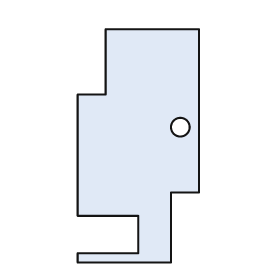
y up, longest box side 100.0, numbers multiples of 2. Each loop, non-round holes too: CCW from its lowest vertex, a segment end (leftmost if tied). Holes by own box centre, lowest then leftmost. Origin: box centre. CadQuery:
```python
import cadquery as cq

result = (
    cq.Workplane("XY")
    .moveTo(-26.0, -50.0)
    .lineTo(14.0, -50.0)
    .lineTo(14.0, -20.0)
    .lineTo(26.0, -20.0)
    .lineTo(26.0, 50.0)
    .lineTo(-14.0, 50.0)
    .lineTo(-14.0, 22.0)
    .lineTo(-26.0, 22.0)
    .lineTo(-26.0, -30.0)
    .lineTo(0.0, -30.0)
    .lineTo(0.0, -46.0)
    .lineTo(-26.0, -46.0)
    .close()
    .moveTo(18.0, 8.0)
    .circle(4.0)
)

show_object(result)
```